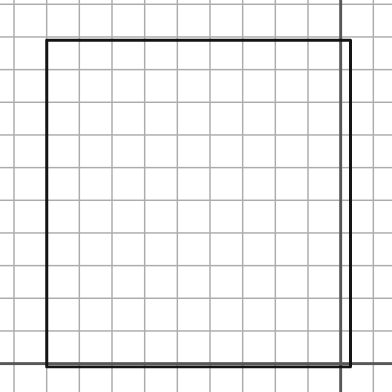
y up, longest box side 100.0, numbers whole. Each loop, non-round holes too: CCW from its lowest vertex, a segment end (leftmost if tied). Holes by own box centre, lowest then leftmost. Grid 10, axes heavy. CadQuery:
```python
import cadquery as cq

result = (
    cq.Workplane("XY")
    .moveTo(-90.0, -1.0)
    .lineTo(3.0, -1.0)
    .lineTo(3.0, 99.0)
    .lineTo(-90.0, 99.0)
    .close()
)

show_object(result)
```